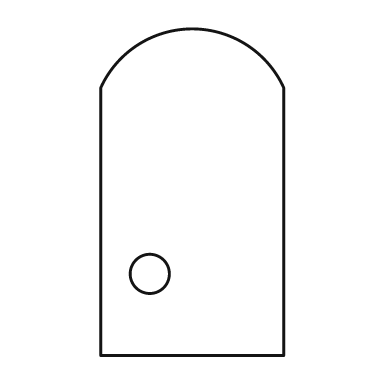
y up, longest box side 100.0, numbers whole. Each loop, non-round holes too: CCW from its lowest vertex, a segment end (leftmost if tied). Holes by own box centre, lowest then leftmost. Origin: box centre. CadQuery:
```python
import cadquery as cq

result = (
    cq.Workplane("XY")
    .moveTo(-28.0, -50.0)
    .lineTo(28.0, -50.0)
    .lineTo(28.0, 32.0)
    .threePointArc((0.0, 50.0), (-28.0, 32.0))
    .close()
    .moveTo(-13.0, -25.0)
    .circle(6.0)
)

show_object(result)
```